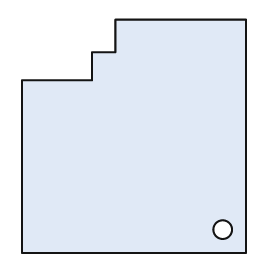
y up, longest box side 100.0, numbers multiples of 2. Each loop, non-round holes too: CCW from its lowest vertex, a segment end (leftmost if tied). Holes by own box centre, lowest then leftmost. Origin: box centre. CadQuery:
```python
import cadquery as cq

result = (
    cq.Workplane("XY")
    .moveTo(-48.0, -50.0)
    .lineTo(48.0, -50.0)
    .lineTo(48.0, 50.0)
    .lineTo(-8.0, 50.0)
    .lineTo(-8.0, 36.0)
    .lineTo(-18.0, 36.0)
    .lineTo(-18.0, 24.0)
    .lineTo(-48.0, 24.0)
    .close()
    .moveTo(38.0, -40.0)
    .circle(4.0)
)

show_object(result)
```